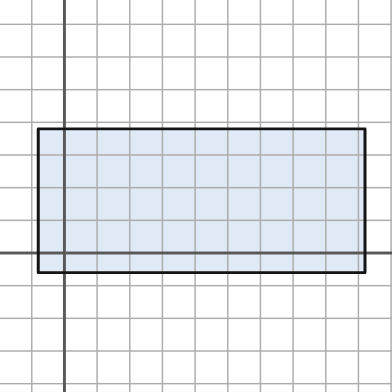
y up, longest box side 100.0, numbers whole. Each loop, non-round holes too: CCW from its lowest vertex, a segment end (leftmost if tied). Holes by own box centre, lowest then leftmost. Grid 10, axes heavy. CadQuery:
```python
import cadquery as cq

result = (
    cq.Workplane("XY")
    .moveTo(-8.0, -6.0)
    .lineTo(92.0, -6.0)
    .lineTo(92.0, 38.0)
    .lineTo(-8.0, 38.0)
    .close()
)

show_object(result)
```